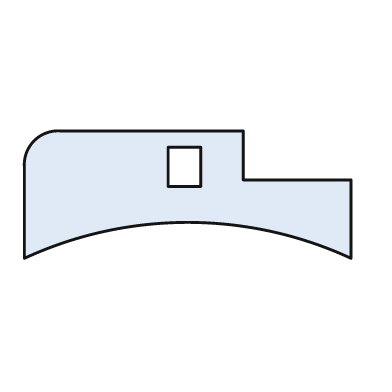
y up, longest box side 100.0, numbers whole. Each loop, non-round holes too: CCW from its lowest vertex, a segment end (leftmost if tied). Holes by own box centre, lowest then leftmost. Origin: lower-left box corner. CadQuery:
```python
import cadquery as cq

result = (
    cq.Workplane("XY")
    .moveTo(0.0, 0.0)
    .threePointArc((50.0, 11.0), (100.0, 0.0))
    .lineTo(100.0, 24.0)
    .lineTo(67.0, 24.0)
    .lineTo(67.0, 39.0)
    .lineTo(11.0, 39.0)
    .threePointArc((3.0, 36.0), (0.0, 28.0))
    .close()
    .moveTo(44.0, 22.0)
    .lineTo(54.0, 22.0)
    .lineTo(54.0, 34.0)
    .lineTo(44.0, 34.0)
    .close()
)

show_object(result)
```